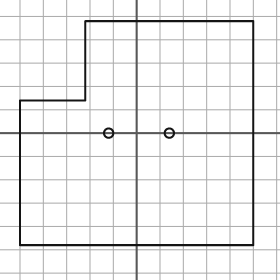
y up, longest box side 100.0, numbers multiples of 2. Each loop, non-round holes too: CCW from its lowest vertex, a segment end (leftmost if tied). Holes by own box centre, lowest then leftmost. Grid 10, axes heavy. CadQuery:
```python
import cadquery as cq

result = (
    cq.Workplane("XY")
    .moveTo(-50.0, -48.0)
    .lineTo(50.0, -48.0)
    .lineTo(50.0, 48.0)
    .lineTo(-22.0, 48.0)
    .lineTo(-22.0, 14.0)
    .lineTo(-50.0, 14.0)
    .close()
    .moveTo(-12.0, 0.0)
    .circle(2.0)
    .moveTo(14.0, 0.0)
    .circle(2.0)
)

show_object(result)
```